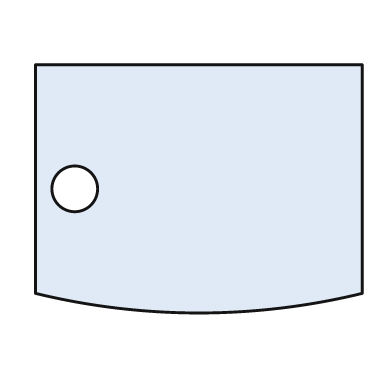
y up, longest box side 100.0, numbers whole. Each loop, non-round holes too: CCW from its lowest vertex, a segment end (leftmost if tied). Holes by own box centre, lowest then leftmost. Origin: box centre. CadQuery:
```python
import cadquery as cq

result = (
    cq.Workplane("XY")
    .moveTo(-50.0, -32.0)
    .threePointArc((0.0, -38.0), (50.0, -32.0))
    .lineTo(50.0, 38.0)
    .lineTo(-50.0, 38.0)
    .close()
    .moveTo(-38.0, 0.0)
    .circle(7.0)
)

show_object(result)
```